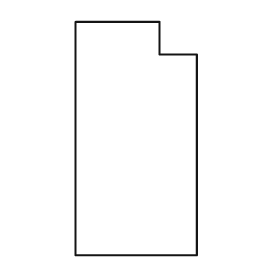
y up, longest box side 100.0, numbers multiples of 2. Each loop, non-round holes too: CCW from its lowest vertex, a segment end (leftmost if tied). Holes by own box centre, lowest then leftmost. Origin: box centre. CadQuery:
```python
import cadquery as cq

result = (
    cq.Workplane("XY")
    .moveTo(-26.0, -50.0)
    .lineTo(26.0, -50.0)
    .lineTo(26.0, 36.0)
    .lineTo(10.0, 36.0)
    .lineTo(10.0, 50.0)
    .lineTo(-26.0, 50.0)
    .close()
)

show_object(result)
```